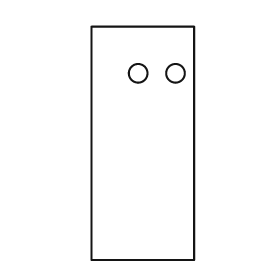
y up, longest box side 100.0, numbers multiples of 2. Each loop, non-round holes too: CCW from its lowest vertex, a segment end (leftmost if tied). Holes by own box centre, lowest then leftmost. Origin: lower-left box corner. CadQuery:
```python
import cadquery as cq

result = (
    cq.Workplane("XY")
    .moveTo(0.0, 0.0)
    .lineTo(44.0, 0.0)
    .lineTo(44.0, 100.0)
    .lineTo(0.0, 100.0)
    .close()
    .moveTo(20.0, 80.0)
    .circle(4.0)
    .moveTo(36.0, 80.0)
    .circle(4.0)
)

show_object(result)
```